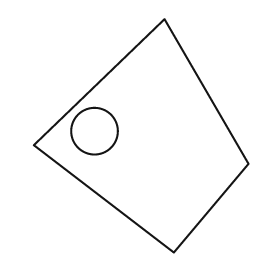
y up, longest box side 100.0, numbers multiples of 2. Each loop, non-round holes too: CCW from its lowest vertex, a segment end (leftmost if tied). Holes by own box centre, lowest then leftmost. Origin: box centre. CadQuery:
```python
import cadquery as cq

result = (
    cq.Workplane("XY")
    .moveTo(14.0, -50.0)
    .lineTo(46.0, -12.0)
    .lineTo(10.0, 50.0)
    .lineTo(-46.0, -4.0)
    .close()
    .moveTo(-20.0, 2.0)
    .circle(10.0)
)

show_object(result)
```